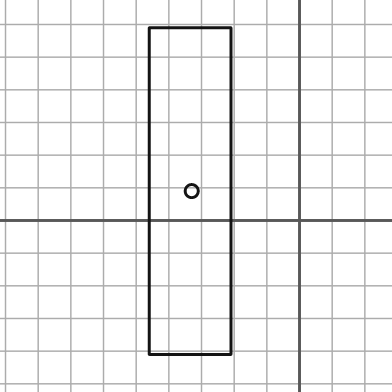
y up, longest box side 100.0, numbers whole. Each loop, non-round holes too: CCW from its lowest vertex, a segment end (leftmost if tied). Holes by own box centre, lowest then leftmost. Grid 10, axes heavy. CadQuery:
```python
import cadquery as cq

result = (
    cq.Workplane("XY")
    .moveTo(-46.0, -41.0)
    .lineTo(-21.0, -41.0)
    .lineTo(-21.0, 59.0)
    .lineTo(-46.0, 59.0)
    .close()
    .moveTo(-33.0, 9.0)
    .circle(2.0)
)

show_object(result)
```